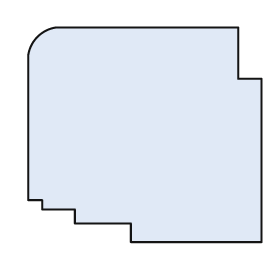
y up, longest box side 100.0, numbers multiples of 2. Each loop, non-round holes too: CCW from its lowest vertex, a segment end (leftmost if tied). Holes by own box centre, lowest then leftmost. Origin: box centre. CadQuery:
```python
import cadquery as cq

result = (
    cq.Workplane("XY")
    .moveTo(-6.0, -46.0)
    .lineTo(50.0, -46.0)
    .lineTo(50.0, 24.0)
    .lineTo(40.0, 24.0)
    .lineTo(40.0, 46.0)
    .lineTo(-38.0, 46.0)
    .threePointArc((-46.0, 42.0), (-50.0, 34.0))
    .lineTo(-50.0, -28.0)
    .lineTo(-44.0, -28.0)
    .lineTo(-44.0, -32.0)
    .lineTo(-30.0, -32.0)
    .lineTo(-30.0, -38.0)
    .lineTo(-6.0, -38.0)
    .close()
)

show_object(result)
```